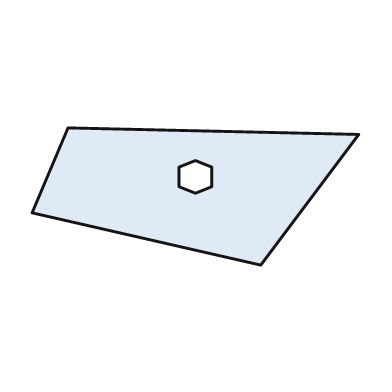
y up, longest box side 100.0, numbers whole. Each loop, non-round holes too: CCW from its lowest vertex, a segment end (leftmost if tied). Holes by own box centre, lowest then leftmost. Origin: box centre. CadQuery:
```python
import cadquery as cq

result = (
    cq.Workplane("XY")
    .moveTo(20.0, -21.0)
    .lineTo(50.0, 19.0)
    .lineTo(-39.0, 21.0)
    .lineTo(-50.0, -5.0)
    .close()
    .moveTo(0.0, 1.0)
    .lineTo(5.0, 3.0)
    .lineTo(5.0, 9.0)
    .lineTo(0.0, 11.0)
    .lineTo(-5.0, 9.0)
    .lineTo(-5.0, 3.0)
    .close()
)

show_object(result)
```